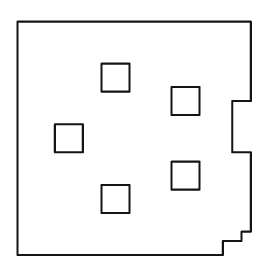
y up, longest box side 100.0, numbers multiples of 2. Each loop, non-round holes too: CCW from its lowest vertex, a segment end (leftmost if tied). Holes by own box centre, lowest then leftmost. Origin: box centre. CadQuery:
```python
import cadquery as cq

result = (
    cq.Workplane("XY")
    .moveTo(-50.0, -50.0)
    .lineTo(38.0, -50.0)
    .lineTo(38.0, -44.0)
    .lineTo(46.0, -44.0)
    .lineTo(46.0, -40.0)
    .lineTo(50.0, -40.0)
    .lineTo(50.0, -6.0)
    .lineTo(42.0, -6.0)
    .lineTo(42.0, 16.0)
    .lineTo(50.0, 16.0)
    .lineTo(50.0, 50.0)
    .lineTo(-50.0, 50.0)
    .close()
    .moveTo(-14.0, -32.0)
    .lineTo(-2.0, -32.0)
    .lineTo(-2.0, -20.0)
    .lineTo(-14.0, -20.0)
    .close()
    .moveTo(16.0, -22.0)
    .lineTo(28.0, -22.0)
    .lineTo(28.0, -10.0)
    .lineTo(16.0, -10.0)
    .close()
    .moveTo(-34.0, -6.0)
    .lineTo(-22.0, -6.0)
    .lineTo(-22.0, 6.0)
    .lineTo(-34.0, 6.0)
    .close()
    .moveTo(16.0, 10.0)
    .lineTo(28.0, 10.0)
    .lineTo(28.0, 22.0)
    .lineTo(16.0, 22.0)
    .close()
    .moveTo(-14.0, 20.0)
    .lineTo(-2.0, 20.0)
    .lineTo(-2.0, 32.0)
    .lineTo(-14.0, 32.0)
    .close()
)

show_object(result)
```